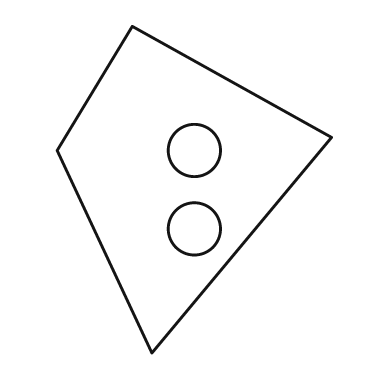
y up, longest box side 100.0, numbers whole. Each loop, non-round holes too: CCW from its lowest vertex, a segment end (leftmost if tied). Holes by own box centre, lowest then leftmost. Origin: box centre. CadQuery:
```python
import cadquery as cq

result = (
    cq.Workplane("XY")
    .moveTo(-13.0, -50.0)
    .lineTo(42.0, 16.0)
    .lineTo(-19.0, 50.0)
    .lineTo(-42.0, 12.0)
    .close()
    .moveTo(0.0, -12.0)
    .circle(8.0)
    .moveTo(0.0, 12.0)
    .circle(8.0)
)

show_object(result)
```